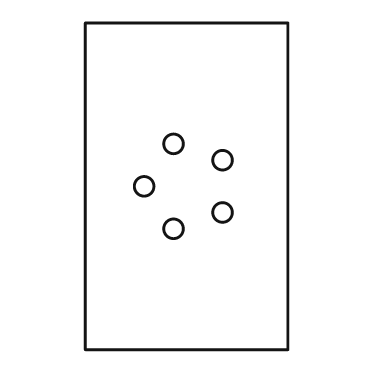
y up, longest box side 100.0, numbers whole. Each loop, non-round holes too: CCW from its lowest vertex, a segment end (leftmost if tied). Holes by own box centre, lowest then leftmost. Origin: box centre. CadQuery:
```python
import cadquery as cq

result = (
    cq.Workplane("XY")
    .moveTo(-31.0, -50.0)
    .lineTo(31.0, -50.0)
    .lineTo(31.0, 50.0)
    .lineTo(-31.0, 50.0)
    .close()
    .moveTo(-4.0, -13.0)
    .circle(3.0)
    .moveTo(11.0, -8.0)
    .circle(3.0)
    .moveTo(-13.0, 0.0)
    .circle(3.0)
    .moveTo(11.0, 8.0)
    .circle(3.0)
    .moveTo(-4.0, 13.0)
    .circle(3.0)
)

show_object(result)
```